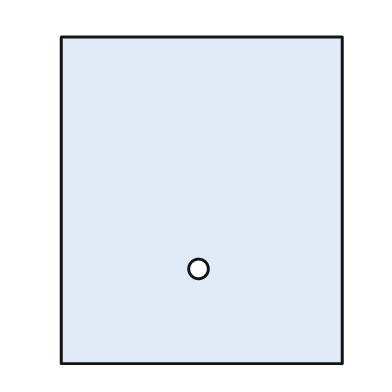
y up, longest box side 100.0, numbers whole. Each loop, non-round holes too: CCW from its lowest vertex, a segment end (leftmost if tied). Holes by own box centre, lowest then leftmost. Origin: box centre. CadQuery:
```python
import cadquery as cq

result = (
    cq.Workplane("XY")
    .moveTo(-43.0, -50.0)
    .lineTo(43.0, -50.0)
    .lineTo(43.0, 50.0)
    .lineTo(-43.0, 50.0)
    .close()
    .moveTo(-1.0, -21.0)
    .circle(3.0)
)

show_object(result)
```